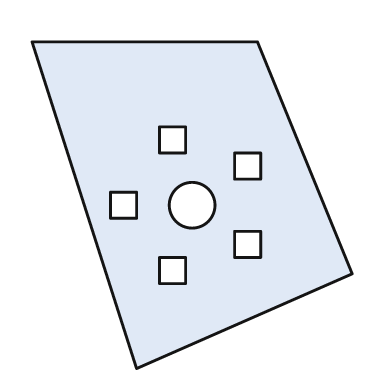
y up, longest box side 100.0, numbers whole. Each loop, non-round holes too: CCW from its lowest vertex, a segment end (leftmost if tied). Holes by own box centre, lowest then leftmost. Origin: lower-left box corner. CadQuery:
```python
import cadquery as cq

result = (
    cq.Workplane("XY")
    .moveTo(32.0, 0.0)
    .lineTo(98.0, 29.0)
    .lineTo(69.0, 100.0)
    .lineTo(0.0, 100.0)
    .close()
    .moveTo(39.0, 26.0)
    .lineTo(47.0, 26.0)
    .lineTo(47.0, 34.0)
    .lineTo(39.0, 34.0)
    .close()
    .moveTo(62.0, 34.0)
    .lineTo(70.0, 34.0)
    .lineTo(70.0, 42.0)
    .lineTo(62.0, 42.0)
    .close()
    .moveTo(24.0, 46.0)
    .lineTo(32.0, 46.0)
    .lineTo(32.0, 54.0)
    .lineTo(24.0, 54.0)
    .close()
    .moveTo(49.0, 50.0)
    .circle(7.0)
    .moveTo(62.0, 58.0)
    .lineTo(70.0, 58.0)
    .lineTo(70.0, 66.0)
    .lineTo(62.0, 66.0)
    .close()
    .moveTo(39.0, 66.0)
    .lineTo(47.0, 66.0)
    .lineTo(47.0, 74.0)
    .lineTo(39.0, 74.0)
    .close()
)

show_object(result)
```